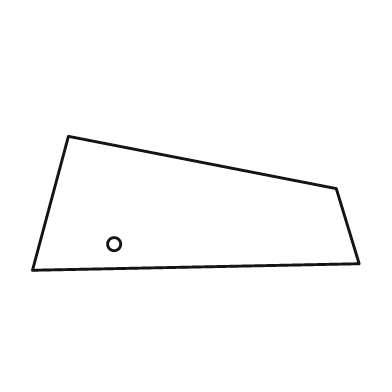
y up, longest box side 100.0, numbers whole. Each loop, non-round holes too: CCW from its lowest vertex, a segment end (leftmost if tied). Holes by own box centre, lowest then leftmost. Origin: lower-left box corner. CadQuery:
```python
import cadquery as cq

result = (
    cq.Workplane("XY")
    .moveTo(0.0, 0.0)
    .lineTo(100.0, 2.0)
    .lineTo(93.0, 25.0)
    .lineTo(11.0, 41.0)
    .close()
    .moveTo(25.0, 8.0)
    .circle(2.0)
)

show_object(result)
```